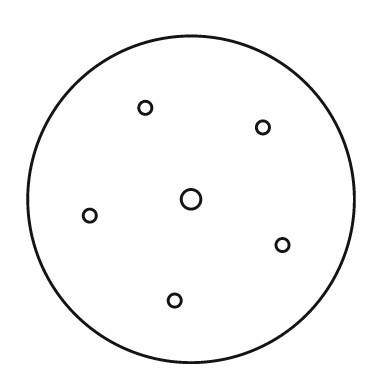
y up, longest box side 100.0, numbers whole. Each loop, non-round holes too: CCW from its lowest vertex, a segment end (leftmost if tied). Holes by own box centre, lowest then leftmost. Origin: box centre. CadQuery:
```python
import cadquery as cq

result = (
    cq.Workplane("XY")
    .moveTo(0.0, 0.0)
    .circle(50.0)
    .moveTo(-5.0, -31.0)
    .circle(2.0)
    .moveTo(28.0, -14.0)
    .circle(2.0)
    .moveTo(-31.0, -5.0)
    .circle(2.0)
    .moveTo(0.0, 0.0)
    .circle(3.0)
    .moveTo(22.0, 22.0)
    .circle(2.0)
    .moveTo(-14.0, 28.0)
    .circle(2.0)
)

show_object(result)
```